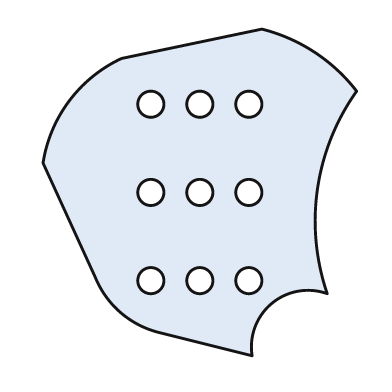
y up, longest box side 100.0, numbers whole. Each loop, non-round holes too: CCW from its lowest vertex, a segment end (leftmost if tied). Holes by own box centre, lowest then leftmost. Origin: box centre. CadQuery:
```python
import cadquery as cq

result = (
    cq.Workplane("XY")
    .moveTo(16.0, -50.0)
    .threePointArc((22.0, -34.0), (39.0, -31.0))
    .threePointArc((36.0, 1.0), (48.0, 31.0))
    .threePointArc((35.0, 43.0), (19.0, 50.0))
    .lineTo(-24.0, 41.0)
    .threePointArc((-40.0, 28.0), (-48.0, 9.0))
    .lineTo(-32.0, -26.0)
    .threePointArc((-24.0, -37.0), (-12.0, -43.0))
    .close()
    .moveTo(-15.0, -27.0)
    .circle(4.0)
    .moveTo(0.0, -27.0)
    .circle(4.0)
    .moveTo(15.0, -27.0)
    .circle(4.0)
    .moveTo(-15.0, 0.0)
    .circle(4.0)
    .moveTo(0.0, 0.0)
    .circle(4.0)
    .moveTo(15.0, 0.0)
    .circle(4.0)
    .moveTo(-15.0, 27.0)
    .circle(4.0)
    .moveTo(0.0, 27.0)
    .circle(4.0)
    .moveTo(15.0, 27.0)
    .circle(4.0)
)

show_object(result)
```